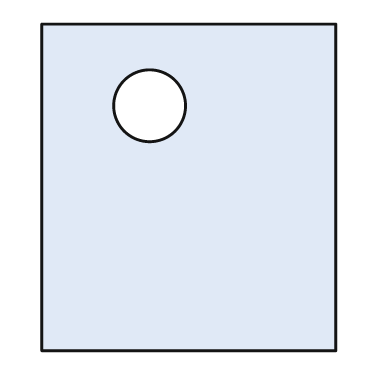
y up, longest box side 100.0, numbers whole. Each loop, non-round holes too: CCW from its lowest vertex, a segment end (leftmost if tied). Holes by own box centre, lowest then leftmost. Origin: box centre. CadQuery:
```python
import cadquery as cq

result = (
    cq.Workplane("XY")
    .moveTo(-45.0, -50.0)
    .lineTo(45.0, -50.0)
    .lineTo(45.0, 50.0)
    .lineTo(-45.0, 50.0)
    .close()
    .moveTo(-12.0, 25.0)
    .circle(11.0)
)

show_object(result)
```